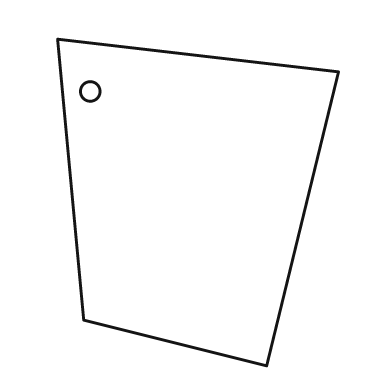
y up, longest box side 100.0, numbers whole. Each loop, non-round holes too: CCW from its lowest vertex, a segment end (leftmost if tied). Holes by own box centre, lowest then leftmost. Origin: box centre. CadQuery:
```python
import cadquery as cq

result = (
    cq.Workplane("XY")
    .moveTo(21.0, -50.0)
    .lineTo(43.0, 40.0)
    .lineTo(-43.0, 50.0)
    .lineTo(-35.0, -36.0)
    .close()
    .moveTo(-33.0, 34.0)
    .circle(3.0)
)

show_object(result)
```